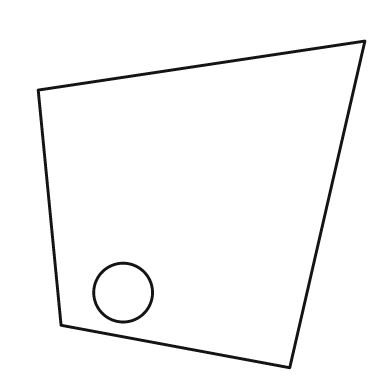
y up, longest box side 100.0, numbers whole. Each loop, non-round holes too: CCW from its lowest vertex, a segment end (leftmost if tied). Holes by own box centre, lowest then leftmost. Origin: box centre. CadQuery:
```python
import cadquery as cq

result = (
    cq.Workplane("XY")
    .moveTo(27.0, -50.0)
    .lineTo(50.0, 50.0)
    .lineTo(-50.0, 35.0)
    .lineTo(-43.0, -37.0)
    .close()
    .moveTo(-24.0, -27.0)
    .circle(9.0)
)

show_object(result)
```